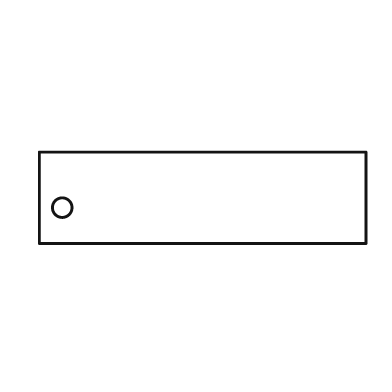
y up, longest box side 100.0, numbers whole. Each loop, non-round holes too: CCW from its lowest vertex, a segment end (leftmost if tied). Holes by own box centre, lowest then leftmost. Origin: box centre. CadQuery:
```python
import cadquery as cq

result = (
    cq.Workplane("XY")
    .moveTo(-50.0, -14.0)
    .lineTo(50.0, -14.0)
    .lineTo(50.0, 14.0)
    .lineTo(-50.0, 14.0)
    .close()
    .moveTo(-43.0, -3.0)
    .circle(3.0)
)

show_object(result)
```